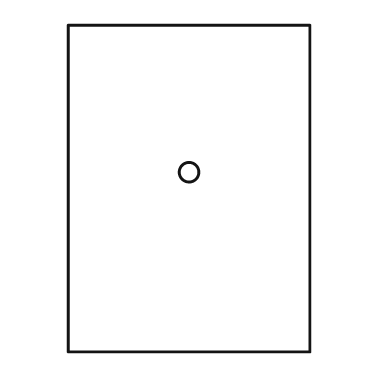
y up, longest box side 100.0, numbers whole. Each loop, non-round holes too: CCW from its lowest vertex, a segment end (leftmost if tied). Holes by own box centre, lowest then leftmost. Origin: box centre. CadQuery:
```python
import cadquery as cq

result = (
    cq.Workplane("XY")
    .moveTo(-37.0, -50.0)
    .lineTo(37.0, -50.0)
    .lineTo(37.0, 50.0)
    .lineTo(-37.0, 50.0)
    .close()
    .moveTo(0.0, 5.0)
    .circle(3.0)
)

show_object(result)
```